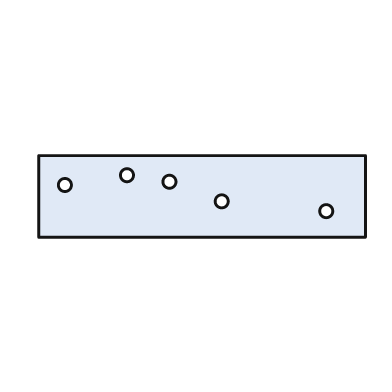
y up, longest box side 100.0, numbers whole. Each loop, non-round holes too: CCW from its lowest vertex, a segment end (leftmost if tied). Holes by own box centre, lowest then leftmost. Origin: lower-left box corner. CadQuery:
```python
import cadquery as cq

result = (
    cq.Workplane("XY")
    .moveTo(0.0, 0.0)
    .lineTo(100.0, 0.0)
    .lineTo(100.0, 25.0)
    .lineTo(0.0, 25.0)
    .close()
    .moveTo(88.0, 8.0)
    .circle(2.0)
    .moveTo(56.0, 11.0)
    .circle(2.0)
    .moveTo(8.0, 16.0)
    .circle(2.0)
    .moveTo(40.0, 17.0)
    .circle(2.0)
    .moveTo(27.0, 19.0)
    .circle(2.0)
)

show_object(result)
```